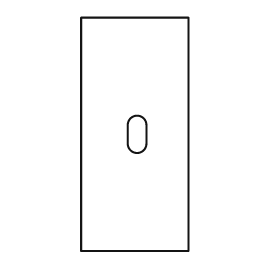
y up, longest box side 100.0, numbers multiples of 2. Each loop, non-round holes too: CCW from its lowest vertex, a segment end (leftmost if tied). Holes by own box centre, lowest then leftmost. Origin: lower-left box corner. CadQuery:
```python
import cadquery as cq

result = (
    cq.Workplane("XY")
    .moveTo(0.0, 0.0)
    .lineTo(46.0, 0.0)
    .lineTo(46.0, 100.0)
    .lineTo(0.0, 100.0)
    .close()
    .moveTo(20.0, 46.0)
    .threePointArc((24.0, 42.0), (28.0, 46.0))
    .lineTo(28.0, 54.0)
    .threePointArc((24.0, 58.0), (20.0, 54.0))
    .close()
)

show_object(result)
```